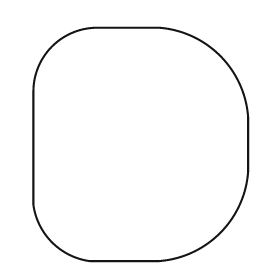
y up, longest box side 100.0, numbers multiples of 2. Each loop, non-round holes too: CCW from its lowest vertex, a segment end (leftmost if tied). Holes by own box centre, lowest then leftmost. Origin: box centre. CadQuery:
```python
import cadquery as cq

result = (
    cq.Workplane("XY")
    .moveTo(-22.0, -50.0)
    .lineTo(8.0, -50.0)
    .threePointArc((34.0, -38.0), (46.0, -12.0))
    .lineTo(46.0, 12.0)
    .threePointArc((34.0, 38.0), (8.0, 50.0))
    .lineTo(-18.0, 50.0)
    .threePointArc((-38.0, 42.0), (-46.0, 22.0))
    .lineTo(-46.0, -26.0)
    .threePointArc((-38.0, -42.0), (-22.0, -50.0))
    .close()
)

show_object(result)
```